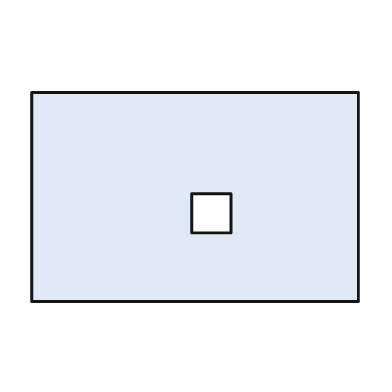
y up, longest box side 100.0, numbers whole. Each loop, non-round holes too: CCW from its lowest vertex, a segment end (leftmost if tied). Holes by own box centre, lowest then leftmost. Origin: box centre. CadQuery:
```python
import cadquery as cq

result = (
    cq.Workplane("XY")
    .moveTo(-50.0, -32.0)
    .lineTo(50.0, -32.0)
    .lineTo(50.0, 32.0)
    .lineTo(-50.0, 32.0)
    .close()
    .moveTo(-1.0, -11.0)
    .lineTo(11.0, -11.0)
    .lineTo(11.0, 1.0)
    .lineTo(-1.0, 1.0)
    .close()
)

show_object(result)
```